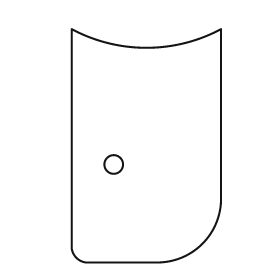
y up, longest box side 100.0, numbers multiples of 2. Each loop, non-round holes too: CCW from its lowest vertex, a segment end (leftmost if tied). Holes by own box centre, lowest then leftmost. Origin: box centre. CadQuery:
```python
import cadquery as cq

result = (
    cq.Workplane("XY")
    .moveTo(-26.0, -50.0)
    .lineTo(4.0, -50.0)
    .threePointArc((24.0, -42.0), (32.0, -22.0))
    .lineTo(32.0, 50.0)
    .threePointArc((0.0, 42.0), (-32.0, 50.0))
    .lineTo(-32.0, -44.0)
    .threePointArc((-30.0, -48.0), (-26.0, -50.0))
    .close()
    .moveTo(-14.0, -8.0)
    .circle(4.0)
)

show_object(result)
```